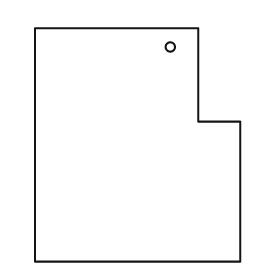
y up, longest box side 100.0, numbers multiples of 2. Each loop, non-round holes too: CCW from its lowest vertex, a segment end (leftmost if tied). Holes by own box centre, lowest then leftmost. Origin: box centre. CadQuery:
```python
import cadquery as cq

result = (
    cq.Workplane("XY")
    .moveTo(-44.0, -50.0)
    .lineTo(44.0, -50.0)
    .lineTo(44.0, 10.0)
    .lineTo(26.0, 10.0)
    .lineTo(26.0, 50.0)
    .lineTo(-44.0, 50.0)
    .close()
    .moveTo(14.0, 42.0)
    .circle(2.0)
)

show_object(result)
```